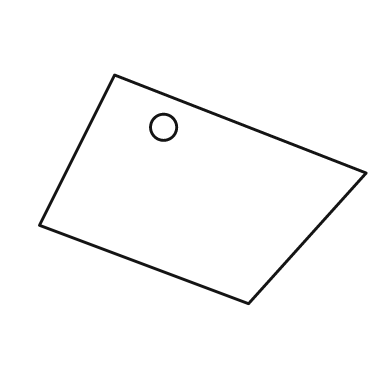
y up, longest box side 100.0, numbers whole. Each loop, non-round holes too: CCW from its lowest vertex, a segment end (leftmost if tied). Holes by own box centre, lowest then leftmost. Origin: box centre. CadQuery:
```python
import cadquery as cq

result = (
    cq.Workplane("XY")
    .moveTo(14.0, -35.0)
    .lineTo(50.0, 5.0)
    .lineTo(-27.0, 35.0)
    .lineTo(-50.0, -11.0)
    .close()
    .moveTo(-12.0, 19.0)
    .circle(4.0)
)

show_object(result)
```